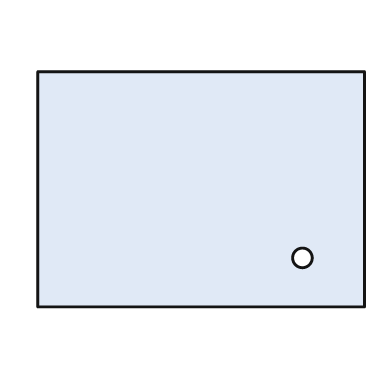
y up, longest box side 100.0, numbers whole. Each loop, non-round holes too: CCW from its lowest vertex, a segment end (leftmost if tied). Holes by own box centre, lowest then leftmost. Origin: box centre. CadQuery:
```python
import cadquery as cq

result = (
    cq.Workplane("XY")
    .moveTo(-50.0, -36.0)
    .lineTo(50.0, -36.0)
    .lineTo(50.0, 36.0)
    .lineTo(-50.0, 36.0)
    .close()
    .moveTo(31.0, -21.0)
    .circle(3.0)
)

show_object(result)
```